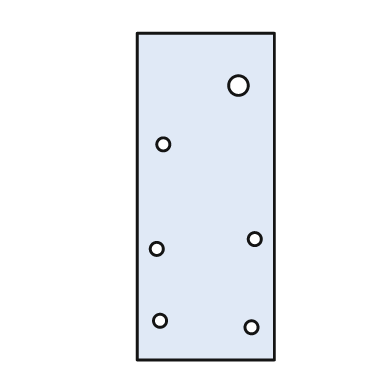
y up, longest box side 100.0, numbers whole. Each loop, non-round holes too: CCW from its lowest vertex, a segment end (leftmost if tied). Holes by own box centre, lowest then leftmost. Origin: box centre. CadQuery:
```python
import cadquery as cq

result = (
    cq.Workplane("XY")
    .moveTo(-21.0, -50.0)
    .lineTo(21.0, -50.0)
    .lineTo(21.0, 50.0)
    .lineTo(-21.0, 50.0)
    .close()
    .moveTo(14.0, -40.0)
    .circle(2.0)
    .moveTo(-14.0, -38.0)
    .circle(2.0)
    .moveTo(-15.0, -16.0)
    .circle(2.0)
    .moveTo(15.0, -13.0)
    .circle(2.0)
    .moveTo(-13.0, 16.0)
    .circle(2.0)
    .moveTo(10.0, 34.0)
    .circle(3.0)
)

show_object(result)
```